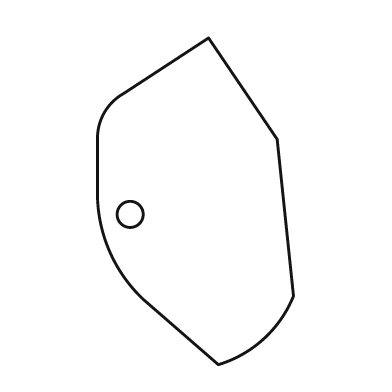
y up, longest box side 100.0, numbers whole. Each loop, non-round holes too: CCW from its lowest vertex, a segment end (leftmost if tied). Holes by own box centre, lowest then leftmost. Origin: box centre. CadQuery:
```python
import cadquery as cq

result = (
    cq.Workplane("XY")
    .moveTo(7.0, -50.0)
    .threePointArc((21.0, -42.0), (30.0, -29.0))
    .lineTo(25.0, 19.0)
    .lineTo(4.0, 50.0)
    .lineTo(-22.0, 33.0)
    .threePointArc((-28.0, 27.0), (-30.0, 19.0))
    .lineTo(-30.0, 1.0)
    .threePointArc((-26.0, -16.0), (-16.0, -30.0))
    .close()
    .moveTo(-20.0, -4.0)
    .circle(4.0)
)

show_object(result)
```